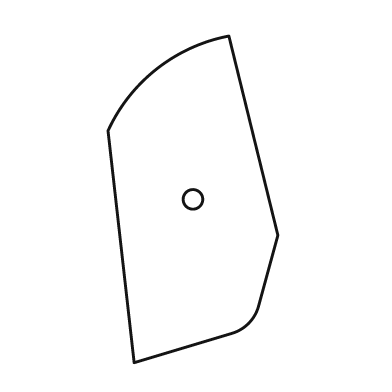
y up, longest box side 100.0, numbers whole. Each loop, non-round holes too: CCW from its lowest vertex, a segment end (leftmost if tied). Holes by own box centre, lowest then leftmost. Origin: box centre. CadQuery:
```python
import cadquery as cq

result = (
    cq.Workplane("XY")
    .moveTo(-18.0, -50.0)
    .lineTo(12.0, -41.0)
    .threePointArc((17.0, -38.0), (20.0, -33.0))
    .lineTo(26.0, -11.0)
    .lineTo(11.0, 50.0)
    .threePointArc((-11.0, 40.0), (-26.0, 21.0))
    .close()
    .moveTo(0.0, 0.0)
    .circle(3.0)
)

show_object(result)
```